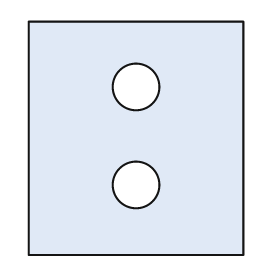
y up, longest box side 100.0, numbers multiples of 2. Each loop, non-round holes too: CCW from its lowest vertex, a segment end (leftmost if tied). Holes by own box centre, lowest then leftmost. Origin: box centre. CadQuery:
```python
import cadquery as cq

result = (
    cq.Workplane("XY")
    .moveTo(-46.0, -50.0)
    .lineTo(46.0, -50.0)
    .lineTo(46.0, 50.0)
    .lineTo(-46.0, 50.0)
    .close()
    .moveTo(0.0, -20.0)
    .circle(10.0)
    .moveTo(0.0, 22.0)
    .circle(10.0)
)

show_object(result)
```